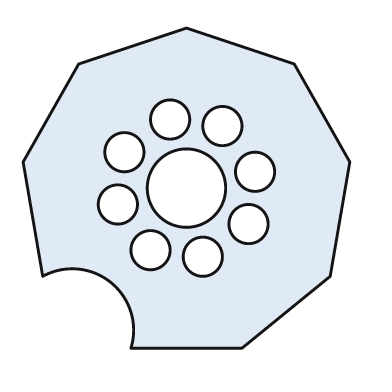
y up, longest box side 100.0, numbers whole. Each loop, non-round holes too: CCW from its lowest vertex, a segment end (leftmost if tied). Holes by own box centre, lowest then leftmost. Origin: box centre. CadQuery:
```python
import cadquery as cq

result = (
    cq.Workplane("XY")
    .moveTo(-17.0, -49.0)
    .lineTo(17.0, -49.0)
    .lineTo(44.0, -27.0)
    .lineTo(50.0, 8.0)
    .lineTo(33.0, 38.0)
    .lineTo(0.0, 49.0)
    .lineTo(-33.0, 38.0)
    .lineTo(-50.0, 8.0)
    .lineTo(-44.0, -27.0)
    .threePointArc((-23.0, -29.0), (-17.0, -49.0))
    .close()
    .moveTo(5.0, -21.0)
    .circle(6.0)
    .moveTo(-11.0, -19.0)
    .circle(6.0)
    .moveTo(19.0, -11.0)
    .circle(6.0)
    .moveTo(-21.0, -5.0)
    .circle(6.0)
    .moveTo(0.0, 0.0)
    .circle(12.0)
    .moveTo(21.0, 5.0)
    .circle(6.0)
    .moveTo(-19.0, 11.0)
    .circle(6.0)
    .moveTo(11.0, 19.0)
    .circle(6.0)
    .moveTo(-5.0, 21.0)
    .circle(6.0)
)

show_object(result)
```